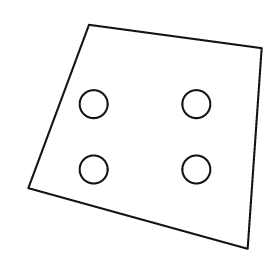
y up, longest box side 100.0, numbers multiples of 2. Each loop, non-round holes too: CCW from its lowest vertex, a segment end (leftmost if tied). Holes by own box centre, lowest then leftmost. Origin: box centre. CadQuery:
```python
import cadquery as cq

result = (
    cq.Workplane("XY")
    .moveTo(44.0, -48.0)
    .lineTo(50.0, 38.0)
    .lineTo(-24.0, 48.0)
    .lineTo(-50.0, -22.0)
    .close()
    .moveTo(-22.0, -14.0)
    .circle(6.0)
    .moveTo(22.0, -14.0)
    .circle(6.0)
    .moveTo(-22.0, 14.0)
    .circle(6.0)
    .moveTo(22.0, 14.0)
    .circle(6.0)
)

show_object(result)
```